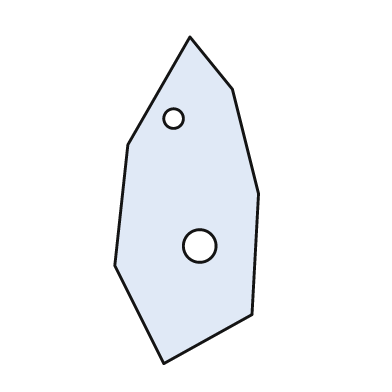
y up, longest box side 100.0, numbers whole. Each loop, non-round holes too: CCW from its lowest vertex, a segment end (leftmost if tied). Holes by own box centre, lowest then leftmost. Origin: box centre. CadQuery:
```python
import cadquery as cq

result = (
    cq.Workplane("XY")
    .moveTo(-7.0, -50.0)
    .lineTo(20.0, -35.0)
    .lineTo(22.0, 2.0)
    .lineTo(14.0, 34.0)
    .lineTo(1.0, 50.0)
    .lineTo(-18.0, 17.0)
    .lineTo(-22.0, -20.0)
    .close()
    .moveTo(4.0, -14.0)
    .circle(5.0)
    .moveTo(-4.0, 25.0)
    .circle(3.0)
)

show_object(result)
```